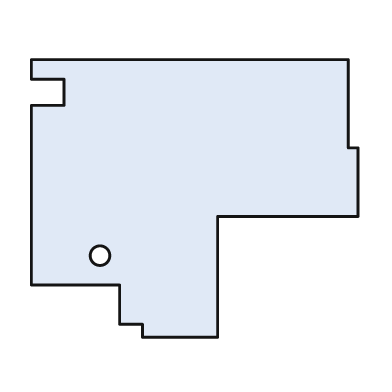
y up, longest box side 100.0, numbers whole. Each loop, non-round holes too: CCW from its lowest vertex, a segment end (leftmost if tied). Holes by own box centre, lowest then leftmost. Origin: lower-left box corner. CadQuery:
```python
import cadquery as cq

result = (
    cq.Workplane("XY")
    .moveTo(34.0, 0.0)
    .lineTo(57.0, 0.0)
    .lineTo(57.0, 37.0)
    .lineTo(100.0, 37.0)
    .lineTo(100.0, 58.0)
    .lineTo(97.0, 58.0)
    .lineTo(97.0, 85.0)
    .lineTo(0.0, 85.0)
    .lineTo(0.0, 79.0)
    .lineTo(10.0, 79.0)
    .lineTo(10.0, 71.0)
    .lineTo(0.0, 71.0)
    .lineTo(0.0, 16.0)
    .lineTo(27.0, 16.0)
    .lineTo(27.0, 4.0)
    .lineTo(34.0, 4.0)
    .close()
    .moveTo(21.0, 25.0)
    .circle(3.0)
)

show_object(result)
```